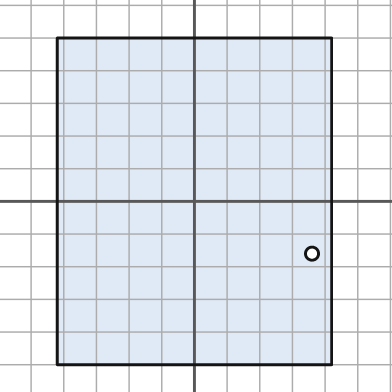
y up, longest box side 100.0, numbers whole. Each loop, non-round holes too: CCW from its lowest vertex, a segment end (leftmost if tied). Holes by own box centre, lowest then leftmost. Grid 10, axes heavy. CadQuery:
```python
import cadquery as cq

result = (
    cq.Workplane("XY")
    .moveTo(-42.0, -50.0)
    .lineTo(42.0, -50.0)
    .lineTo(42.0, 50.0)
    .lineTo(-42.0, 50.0)
    .close()
    .moveTo(36.0, -16.0)
    .circle(2.0)
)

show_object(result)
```